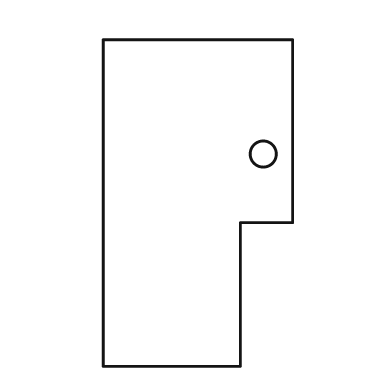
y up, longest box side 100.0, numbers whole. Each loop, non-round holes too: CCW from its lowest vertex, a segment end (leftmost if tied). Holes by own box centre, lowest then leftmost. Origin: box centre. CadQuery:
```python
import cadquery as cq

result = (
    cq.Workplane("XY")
    .moveTo(-29.0, -50.0)
    .lineTo(13.0, -50.0)
    .lineTo(13.0, -6.0)
    .lineTo(29.0, -6.0)
    .lineTo(29.0, 50.0)
    .lineTo(-29.0, 50.0)
    .close()
    .moveTo(20.0, 15.0)
    .circle(4.0)
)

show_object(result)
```